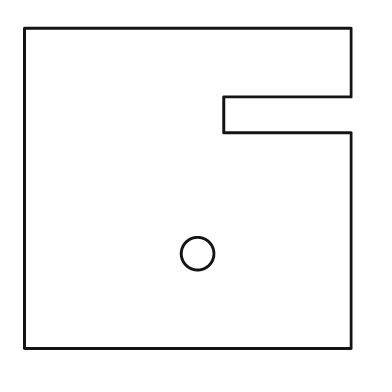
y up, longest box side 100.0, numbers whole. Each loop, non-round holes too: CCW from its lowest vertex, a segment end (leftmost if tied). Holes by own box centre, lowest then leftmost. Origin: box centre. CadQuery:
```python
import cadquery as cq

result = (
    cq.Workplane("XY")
    .moveTo(-50.0, -49.0)
    .lineTo(50.0, -49.0)
    .lineTo(50.0, 17.0)
    .lineTo(11.0, 17.0)
    .lineTo(11.0, 28.0)
    .lineTo(50.0, 28.0)
    .lineTo(50.0, 49.0)
    .lineTo(-50.0, 49.0)
    .close()
    .moveTo(3.0, -20.0)
    .circle(5.0)
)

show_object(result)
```